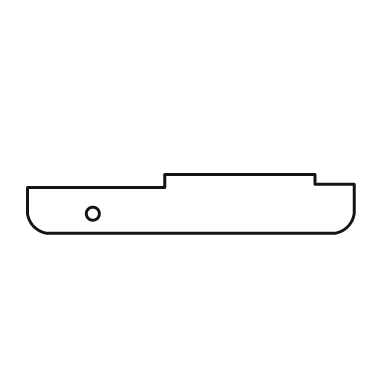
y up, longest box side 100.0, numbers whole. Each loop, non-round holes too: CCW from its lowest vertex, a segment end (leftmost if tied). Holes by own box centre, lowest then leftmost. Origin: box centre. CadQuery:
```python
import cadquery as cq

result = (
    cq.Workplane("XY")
    .moveTo(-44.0, -9.0)
    .lineTo(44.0, -9.0)
    .threePointArc((48.0, -7.0), (50.0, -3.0))
    .lineTo(50.0, 6.0)
    .lineTo(38.0, 6.0)
    .lineTo(38.0, 9.0)
    .lineTo(-8.0, 9.0)
    .lineTo(-8.0, 5.0)
    .lineTo(-50.0, 5.0)
    .lineTo(-50.0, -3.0)
    .threePointArc((-48.0, -7.0), (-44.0, -9.0))
    .close()
    .moveTo(-30.0, -3.0)
    .circle(2.0)
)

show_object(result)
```